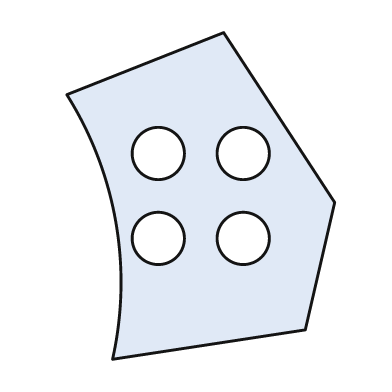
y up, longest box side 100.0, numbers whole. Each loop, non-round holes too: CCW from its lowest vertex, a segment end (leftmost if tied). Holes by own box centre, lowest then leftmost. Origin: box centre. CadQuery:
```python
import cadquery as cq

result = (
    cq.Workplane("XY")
    .moveTo(-27.0, -50.0)
    .lineTo(32.0, -41.0)
    .lineTo(41.0, -2.0)
    .lineTo(7.0, 50.0)
    .lineTo(-41.0, 31.0)
    .threePointArc((-26.0, -8.0), (-27.0, -50.0))
    .close()
    .moveTo(-13.0, -13.0)
    .circle(8.0)
    .moveTo(13.0, -13.0)
    .circle(8.0)
    .moveTo(-13.0, 13.0)
    .circle(8.0)
    .moveTo(13.0, 13.0)
    .circle(8.0)
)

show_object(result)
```